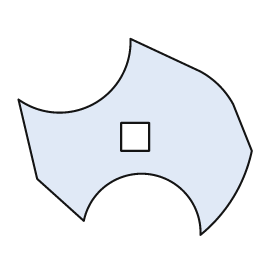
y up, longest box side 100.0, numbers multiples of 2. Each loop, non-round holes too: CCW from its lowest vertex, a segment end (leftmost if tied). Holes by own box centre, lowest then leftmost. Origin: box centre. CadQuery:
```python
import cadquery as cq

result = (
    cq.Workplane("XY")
    .moveTo(28.0, -42.0)
    .threePointArc((42.0, -26.0), (50.0, -6.0))
    .lineTo(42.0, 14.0)
    .threePointArc((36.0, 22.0), (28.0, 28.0))
    .lineTo(-2.0, 42.0)
    .threePointArc((-18.0, 14.0), (-50.0, 16.0))
    .lineTo(-42.0, -18.0)
    .lineTo(-22.0, -36.0)
    .threePointArc((6.0, -16.0), (28.0, -42.0))
    .close()
    .moveTo(-6.0, -6.0)
    .lineTo(6.0, -6.0)
    .lineTo(6.0, 6.0)
    .lineTo(-6.0, 6.0)
    .close()
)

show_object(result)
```